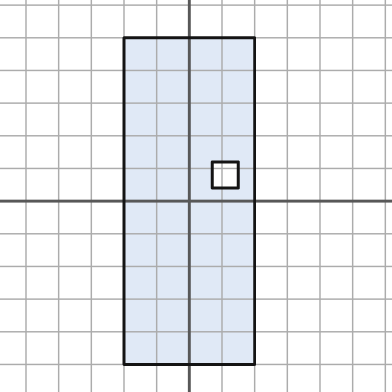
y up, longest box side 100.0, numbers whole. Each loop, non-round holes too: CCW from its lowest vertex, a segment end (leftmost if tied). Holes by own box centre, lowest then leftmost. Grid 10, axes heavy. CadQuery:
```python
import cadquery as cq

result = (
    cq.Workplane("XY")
    .moveTo(-20.0, -50.0)
    .lineTo(20.0, -50.0)
    .lineTo(20.0, 50.0)
    .lineTo(-20.0, 50.0)
    .close()
    .moveTo(7.0, 4.0)
    .lineTo(15.0, 4.0)
    .lineTo(15.0, 12.0)
    .lineTo(7.0, 12.0)
    .close()
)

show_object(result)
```